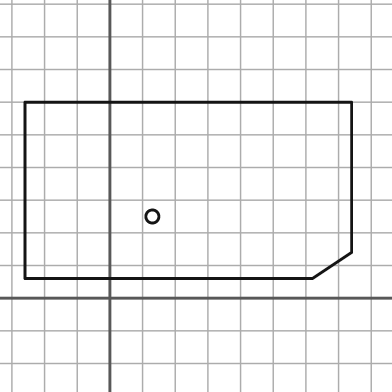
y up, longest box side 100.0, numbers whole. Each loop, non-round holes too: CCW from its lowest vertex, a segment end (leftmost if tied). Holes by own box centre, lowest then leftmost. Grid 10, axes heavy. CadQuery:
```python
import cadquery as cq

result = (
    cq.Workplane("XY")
    .moveTo(-26.0, 6.0)
    .lineTo(62.0, 6.0)
    .lineTo(74.0, 14.0)
    .lineTo(74.0, 60.0)
    .lineTo(-26.0, 60.0)
    .close()
    .moveTo(13.0, 25.0)
    .circle(2.0)
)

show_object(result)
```